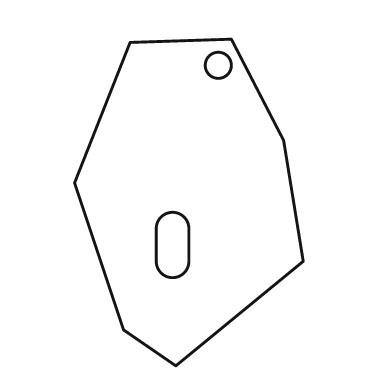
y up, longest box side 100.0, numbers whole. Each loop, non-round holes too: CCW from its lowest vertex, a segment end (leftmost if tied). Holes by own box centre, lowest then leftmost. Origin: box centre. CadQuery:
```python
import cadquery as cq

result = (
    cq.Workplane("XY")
    .moveTo(-4.0, -50.0)
    .lineTo(35.0, -18.0)
    .lineTo(29.0, 19.0)
    .lineTo(13.0, 50.0)
    .lineTo(-18.0, 49.0)
    .lineTo(-35.0, 6.0)
    .lineTo(-20.0, -39.0)
    .close()
    .moveTo(-10.0, -18.0)
    .threePointArc((-5.0, -23.0), (0.0, -18.0))
    .lineTo(0.0, -8.0)
    .threePointArc((-5.0, -3.0), (-10.0, -8.0))
    .close()
    .moveTo(9.0, 42.0)
    .circle(4.0)
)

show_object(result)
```